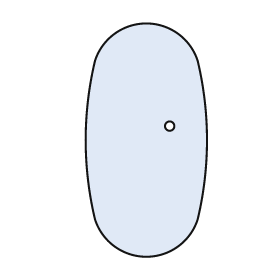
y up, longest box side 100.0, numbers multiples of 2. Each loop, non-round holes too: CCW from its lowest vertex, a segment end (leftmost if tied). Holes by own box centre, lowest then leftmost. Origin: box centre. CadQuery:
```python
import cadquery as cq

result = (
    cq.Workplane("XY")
    .moveTo(-22.0, -34.0)
    .threePointArc((0.0, -50.0), (22.0, -34.0))
    .threePointArc((26.0, 0.0), (22.0, 34.0))
    .threePointArc((0.0, 50.0), (-22.0, 34.0))
    .threePointArc((-26.0, 0.0), (-22.0, -34.0))
    .close()
    .moveTo(10.0, 6.0)
    .circle(2.0)
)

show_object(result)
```